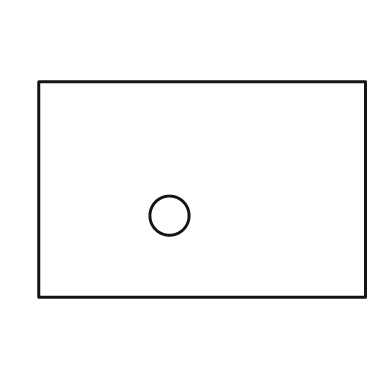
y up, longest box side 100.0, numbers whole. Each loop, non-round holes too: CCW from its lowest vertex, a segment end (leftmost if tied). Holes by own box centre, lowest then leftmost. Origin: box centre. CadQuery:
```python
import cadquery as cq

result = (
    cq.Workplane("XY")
    .moveTo(-50.0, -33.0)
    .lineTo(50.0, -33.0)
    .lineTo(50.0, 33.0)
    .lineTo(-50.0, 33.0)
    .close()
    .moveTo(-10.0, -8.0)
    .circle(6.0)
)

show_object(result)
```